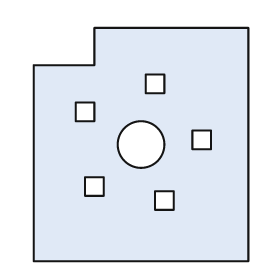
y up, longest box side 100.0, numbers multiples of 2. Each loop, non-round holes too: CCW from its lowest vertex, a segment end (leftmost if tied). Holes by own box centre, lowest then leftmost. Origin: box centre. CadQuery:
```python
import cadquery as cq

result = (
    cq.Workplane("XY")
    .moveTo(-46.0, -50.0)
    .lineTo(46.0, -50.0)
    .lineTo(46.0, 50.0)
    .lineTo(-20.0, 50.0)
    .lineTo(-20.0, 34.0)
    .lineTo(-46.0, 34.0)
    .close()
    .moveTo(6.0, -28.0)
    .lineTo(14.0, -28.0)
    .lineTo(14.0, -20.0)
    .lineTo(6.0, -20.0)
    .close()
    .moveTo(-24.0, -22.0)
    .lineTo(-16.0, -22.0)
    .lineTo(-16.0, -14.0)
    .lineTo(-24.0, -14.0)
    .close()
    .moveTo(0.0, 0.0)
    .circle(10.0)
    .moveTo(22.0, -2.0)
    .lineTo(30.0, -2.0)
    .lineTo(30.0, 6.0)
    .lineTo(22.0, 6.0)
    .close()
    .moveTo(-28.0, 10.0)
    .lineTo(-20.0, 10.0)
    .lineTo(-20.0, 18.0)
    .lineTo(-28.0, 18.0)
    .close()
    .moveTo(2.0, 22.0)
    .lineTo(10.0, 22.0)
    .lineTo(10.0, 30.0)
    .lineTo(2.0, 30.0)
    .close()
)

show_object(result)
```